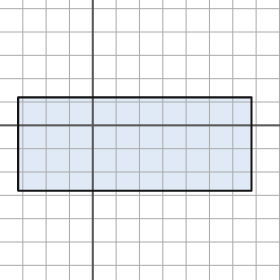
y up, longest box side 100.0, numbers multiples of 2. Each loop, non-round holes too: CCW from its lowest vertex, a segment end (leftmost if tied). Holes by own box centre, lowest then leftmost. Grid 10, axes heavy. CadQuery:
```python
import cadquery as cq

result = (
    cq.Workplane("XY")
    .moveTo(-32.0, -28.0)
    .lineTo(68.0, -28.0)
    .lineTo(68.0, 12.0)
    .lineTo(-32.0, 12.0)
    .close()
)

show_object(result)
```